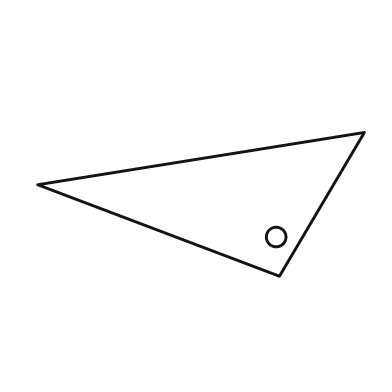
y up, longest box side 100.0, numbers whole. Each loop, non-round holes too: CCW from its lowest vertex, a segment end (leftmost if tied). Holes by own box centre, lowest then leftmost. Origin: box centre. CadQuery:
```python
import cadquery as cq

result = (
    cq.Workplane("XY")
    .moveTo(24.0, -22.0)
    .lineTo(50.0, 22.0)
    .lineTo(-50.0, 6.0)
    .close()
    .moveTo(23.0, -10.0)
    .circle(3.0)
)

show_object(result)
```